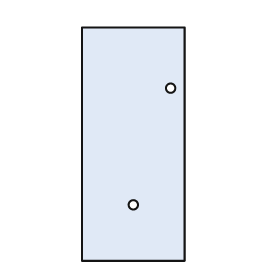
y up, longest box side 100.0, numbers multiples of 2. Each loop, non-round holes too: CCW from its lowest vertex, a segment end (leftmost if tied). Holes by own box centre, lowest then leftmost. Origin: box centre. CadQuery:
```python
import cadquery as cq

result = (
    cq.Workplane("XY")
    .moveTo(-22.0, -50.0)
    .lineTo(22.0, -50.0)
    .lineTo(22.0, 50.0)
    .lineTo(-22.0, 50.0)
    .close()
    .moveTo(0.0, -26.0)
    .circle(2.0)
    .moveTo(16.0, 24.0)
    .circle(2.0)
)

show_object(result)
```